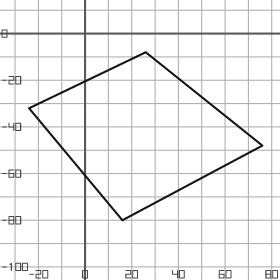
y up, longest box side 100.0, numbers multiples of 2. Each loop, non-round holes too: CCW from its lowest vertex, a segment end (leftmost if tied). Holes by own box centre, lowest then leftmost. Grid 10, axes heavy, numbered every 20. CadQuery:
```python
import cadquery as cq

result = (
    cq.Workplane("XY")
    .moveTo(16.0, -80.0)
    .lineTo(76.0, -48.0)
    .lineTo(26.0, -8.0)
    .lineTo(-24.0, -32.0)
    .close()
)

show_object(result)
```